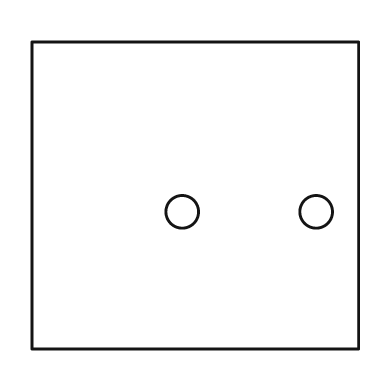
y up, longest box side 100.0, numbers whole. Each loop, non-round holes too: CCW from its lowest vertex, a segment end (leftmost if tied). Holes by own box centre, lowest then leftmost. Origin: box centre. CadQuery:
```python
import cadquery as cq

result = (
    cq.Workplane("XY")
    .moveTo(-50.0, -47.0)
    .lineTo(50.0, -47.0)
    .lineTo(50.0, 47.0)
    .lineTo(-50.0, 47.0)
    .close()
    .moveTo(-4.0, -5.0)
    .circle(5.0)
    .moveTo(37.0, -5.0)
    .circle(5.0)
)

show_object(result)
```